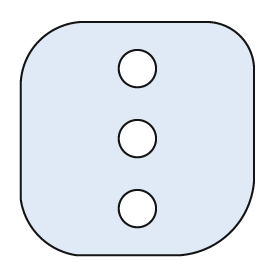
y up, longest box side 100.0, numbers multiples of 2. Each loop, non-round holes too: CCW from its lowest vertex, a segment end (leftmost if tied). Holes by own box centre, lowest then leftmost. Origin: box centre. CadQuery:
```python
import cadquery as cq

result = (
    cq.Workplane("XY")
    .moveTo(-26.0, -50.0)
    .lineTo(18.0, -50.0)
    .threePointArc((40.0, -40.0), (50.0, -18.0))
    .lineTo(50.0, 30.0)
    .threePointArc((44.0, 44.0), (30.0, 50.0))
    .lineTo(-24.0, 50.0)
    .threePointArc((-42.0, 42.0), (-50.0, 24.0))
    .lineTo(-50.0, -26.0)
    .threePointArc((-42.0, -42.0), (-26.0, -50.0))
    .close()
    .moveTo(0.0, -30.0)
    .circle(8.0)
    .moveTo(0.0, 0.0)
    .circle(8.0)
    .moveTo(0.0, 30.0)
    .circle(8.0)
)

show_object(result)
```